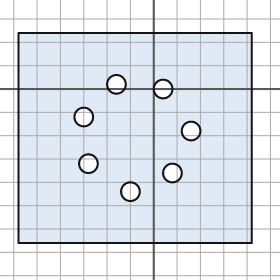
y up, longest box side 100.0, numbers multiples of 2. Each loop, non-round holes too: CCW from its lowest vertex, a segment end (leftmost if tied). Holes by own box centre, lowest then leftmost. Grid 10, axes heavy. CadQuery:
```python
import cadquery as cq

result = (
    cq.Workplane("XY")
    .moveTo(-58.0, -66.0)
    .lineTo(42.0, -66.0)
    .lineTo(42.0, 24.0)
    .lineTo(-58.0, 24.0)
    .close()
    .moveTo(-10.0, -44.0)
    .circle(4.0)
    .moveTo(8.0, -36.0)
    .circle(4.0)
    .moveTo(-28.0, -32.0)
    .circle(4.0)
    .moveTo(16.0, -18.0)
    .circle(4.0)
    .moveTo(-30.0, -12.0)
    .circle(4.0)
    .moveTo(4.0, 0.0)
    .circle(4.0)
    .moveTo(-16.0, 2.0)
    .circle(4.0)
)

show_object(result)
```